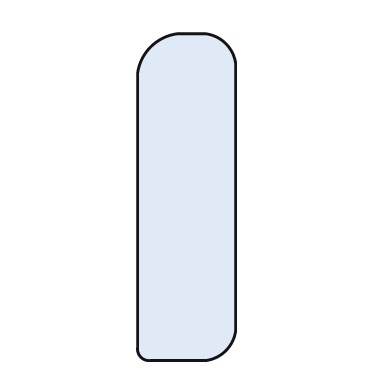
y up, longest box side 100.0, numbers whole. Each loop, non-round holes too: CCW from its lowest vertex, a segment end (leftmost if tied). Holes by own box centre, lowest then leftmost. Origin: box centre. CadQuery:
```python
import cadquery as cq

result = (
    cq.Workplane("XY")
    .moveTo(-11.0, -50.0)
    .lineTo(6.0, -50.0)
    .threePointArc((12.0, -47.0), (15.0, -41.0))
    .lineTo(15.0, 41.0)
    .threePointArc((12.0, 47.0), (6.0, 50.0))
    .lineTo(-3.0, 50.0)
    .threePointArc((-11.0, 46.0), (-15.0, 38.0))
    .lineTo(-15.0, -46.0)
    .threePointArc((-14.0, -49.0), (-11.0, -50.0))
    .close()
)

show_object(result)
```